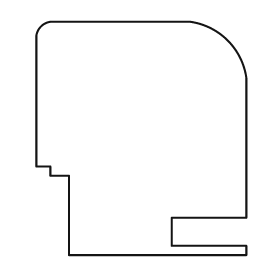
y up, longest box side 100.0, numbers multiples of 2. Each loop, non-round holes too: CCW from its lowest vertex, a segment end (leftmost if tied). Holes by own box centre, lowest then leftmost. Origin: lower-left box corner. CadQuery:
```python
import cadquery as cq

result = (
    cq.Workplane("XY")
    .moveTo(14.0, 0.0)
    .lineTo(90.0, 0.0)
    .lineTo(90.0, 4.0)
    .lineTo(58.0, 4.0)
    .lineTo(58.0, 16.0)
    .lineTo(90.0, 16.0)
    .lineTo(90.0, 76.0)
    .threePointArc((82.0, 92.0), (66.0, 100.0))
    .lineTo(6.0, 100.0)
    .threePointArc((2.0, 98.0), (0.0, 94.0))
    .lineTo(0.0, 38.0)
    .lineTo(6.0, 38.0)
    .lineTo(6.0, 34.0)
    .lineTo(14.0, 34.0)
    .close()
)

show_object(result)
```